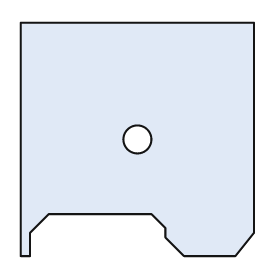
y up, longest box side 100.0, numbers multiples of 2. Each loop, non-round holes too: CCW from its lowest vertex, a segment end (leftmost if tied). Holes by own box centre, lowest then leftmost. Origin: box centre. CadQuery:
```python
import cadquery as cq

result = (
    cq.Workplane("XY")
    .moveTo(-50.0, -50.0)
    .lineTo(-46.0, -50.0)
    .lineTo(-46.0, -40.0)
    .lineTo(-38.0, -32.0)
    .lineTo(6.0, -32.0)
    .lineTo(12.0, -38.0)
    .lineTo(12.0, -42.0)
    .lineTo(20.0, -50.0)
    .lineTo(42.0, -50.0)
    .lineTo(50.0, -40.0)
    .lineTo(50.0, 50.0)
    .lineTo(-50.0, 50.0)
    .close()
    .moveTo(0.0, 0.0)
    .circle(6.0)
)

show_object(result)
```